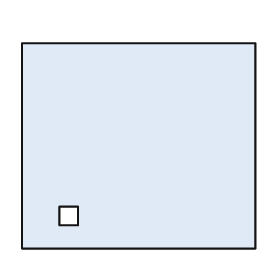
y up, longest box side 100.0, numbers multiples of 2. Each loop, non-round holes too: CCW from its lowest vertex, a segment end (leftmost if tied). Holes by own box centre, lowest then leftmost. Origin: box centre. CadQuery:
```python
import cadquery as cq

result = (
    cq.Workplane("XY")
    .moveTo(-50.0, -44.0)
    .lineTo(50.0, -44.0)
    .lineTo(50.0, 44.0)
    .lineTo(-50.0, 44.0)
    .close()
    .moveTo(-34.0, -34.0)
    .lineTo(-26.0, -34.0)
    .lineTo(-26.0, -26.0)
    .lineTo(-34.0, -26.0)
    .close()
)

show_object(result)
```